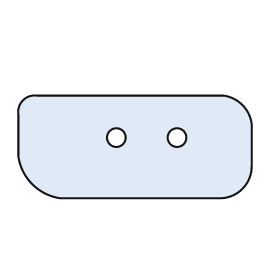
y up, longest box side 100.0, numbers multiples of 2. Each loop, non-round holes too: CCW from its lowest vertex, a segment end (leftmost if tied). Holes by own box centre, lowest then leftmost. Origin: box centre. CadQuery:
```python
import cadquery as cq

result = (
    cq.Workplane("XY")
    .moveTo(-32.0, -22.0)
    .lineTo(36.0, -22.0)
    .threePointArc((46.0, -18.0), (50.0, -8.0))
    .lineTo(50.0, 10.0)
    .threePointArc((46.0, 18.0), (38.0, 22.0))
    .lineTo(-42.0, 22.0)
    .threePointArc((-48.0, 20.0), (-50.0, 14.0))
    .lineTo(-50.0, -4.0)
    .threePointArc((-44.0, -16.0), (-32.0, -22.0))
    .close()
    .moveTo(-8.0, 4.0)
    .circle(4.0)
    .moveTo(18.0, 4.0)
    .circle(4.0)
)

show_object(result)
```